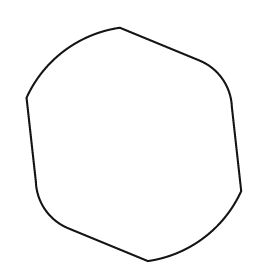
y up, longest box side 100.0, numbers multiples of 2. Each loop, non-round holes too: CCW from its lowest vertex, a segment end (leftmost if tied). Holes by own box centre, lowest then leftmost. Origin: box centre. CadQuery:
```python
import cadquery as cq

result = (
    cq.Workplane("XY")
    .moveTo(6.0, -50.0)
    .threePointArc((30.0, -40.0), (46.0, -20.0))
    .lineTo(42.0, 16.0)
    .threePointArc((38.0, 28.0), (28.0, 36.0))
    .lineTo(-6.0, 50.0)
    .threePointArc((-30.0, 40.0), (-46.0, 20.0))
    .lineTo(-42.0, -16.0)
    .threePointArc((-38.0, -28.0), (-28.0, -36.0))
    .close()
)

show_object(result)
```